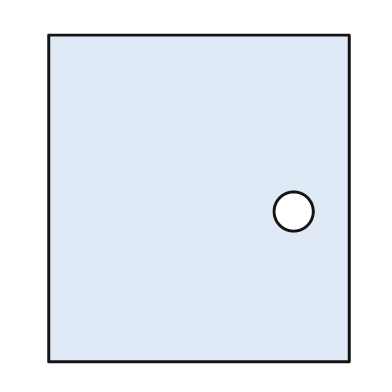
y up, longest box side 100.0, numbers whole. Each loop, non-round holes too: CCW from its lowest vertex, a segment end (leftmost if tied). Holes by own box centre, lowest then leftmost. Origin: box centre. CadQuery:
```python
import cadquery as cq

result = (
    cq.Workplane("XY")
    .moveTo(-46.0, -50.0)
    .lineTo(46.0, -50.0)
    .lineTo(46.0, 50.0)
    .lineTo(-46.0, 50.0)
    .close()
    .moveTo(29.0, -4.0)
    .circle(6.0)
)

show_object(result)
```